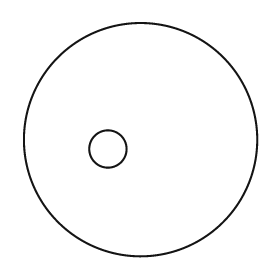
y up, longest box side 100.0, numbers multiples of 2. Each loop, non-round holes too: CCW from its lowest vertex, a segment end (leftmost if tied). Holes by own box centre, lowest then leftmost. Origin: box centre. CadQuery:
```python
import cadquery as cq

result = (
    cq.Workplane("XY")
    .moveTo(0.0, 0.0)
    .circle(50.0)
    .moveTo(-14.0, -4.0)
    .circle(8.0)
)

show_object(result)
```